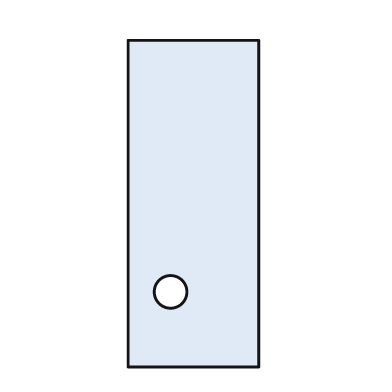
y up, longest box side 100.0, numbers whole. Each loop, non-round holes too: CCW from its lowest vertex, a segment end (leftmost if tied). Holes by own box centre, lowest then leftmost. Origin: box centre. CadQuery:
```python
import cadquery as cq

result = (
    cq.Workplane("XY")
    .moveTo(-20.0, -50.0)
    .lineTo(20.0, -50.0)
    .lineTo(20.0, 50.0)
    .lineTo(-20.0, 50.0)
    .close()
    .moveTo(-7.0, -27.0)
    .circle(5.0)
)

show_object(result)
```